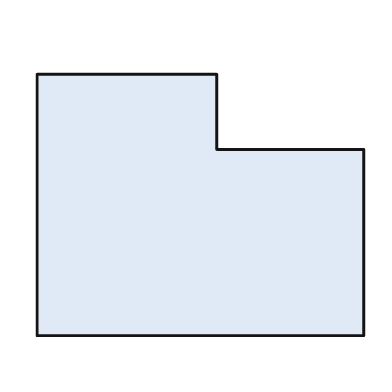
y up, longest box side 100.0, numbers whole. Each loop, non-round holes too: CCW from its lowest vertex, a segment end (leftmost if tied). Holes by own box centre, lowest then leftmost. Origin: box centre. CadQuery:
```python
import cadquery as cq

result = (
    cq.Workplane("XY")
    .moveTo(-50.0, -40.0)
    .lineTo(50.0, -40.0)
    .lineTo(50.0, 17.0)
    .lineTo(5.0, 17.0)
    .lineTo(5.0, 40.0)
    .lineTo(-50.0, 40.0)
    .close()
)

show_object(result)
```